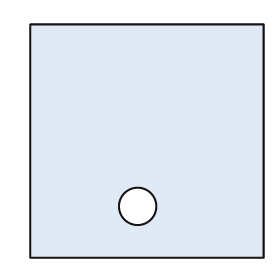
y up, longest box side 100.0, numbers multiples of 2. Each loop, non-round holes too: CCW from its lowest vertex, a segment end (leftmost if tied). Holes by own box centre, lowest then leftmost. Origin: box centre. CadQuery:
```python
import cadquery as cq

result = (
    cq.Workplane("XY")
    .moveTo(-50.0, -50.0)
    .lineTo(50.0, -50.0)
    .lineTo(50.0, 50.0)
    .lineTo(-50.0, 50.0)
    .close()
    .moveTo(-4.0, -28.0)
    .circle(8.0)
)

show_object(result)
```